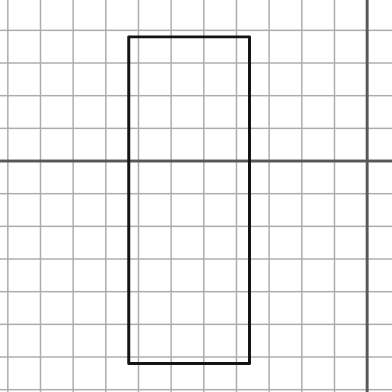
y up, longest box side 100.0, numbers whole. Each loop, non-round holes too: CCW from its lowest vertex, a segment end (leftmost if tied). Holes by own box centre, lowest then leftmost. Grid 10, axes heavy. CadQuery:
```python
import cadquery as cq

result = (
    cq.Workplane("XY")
    .moveTo(-73.0, -62.0)
    .lineTo(-36.0, -62.0)
    .lineTo(-36.0, 38.0)
    .lineTo(-73.0, 38.0)
    .close()
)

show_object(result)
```